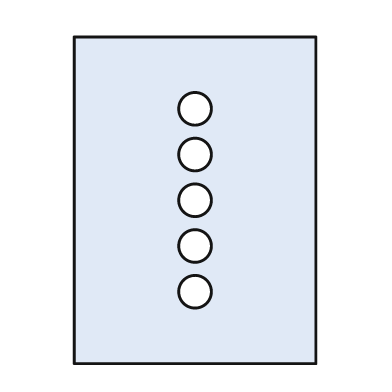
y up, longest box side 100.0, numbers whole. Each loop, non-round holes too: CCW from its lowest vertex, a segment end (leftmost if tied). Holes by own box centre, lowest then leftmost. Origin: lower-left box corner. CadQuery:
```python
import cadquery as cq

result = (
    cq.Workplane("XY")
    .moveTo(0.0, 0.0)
    .lineTo(74.0, 0.0)
    .lineTo(74.0, 100.0)
    .lineTo(0.0, 100.0)
    .close()
    .moveTo(37.0, 22.0)
    .circle(5.0)
    .moveTo(37.0, 36.0)
    .circle(5.0)
    .moveTo(37.0, 50.0)
    .circle(5.0)
    .moveTo(37.0, 64.0)
    .circle(5.0)
    .moveTo(37.0, 78.0)
    .circle(5.0)
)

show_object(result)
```